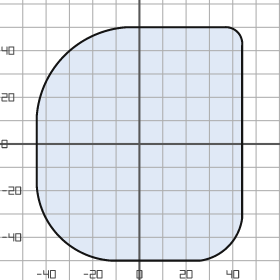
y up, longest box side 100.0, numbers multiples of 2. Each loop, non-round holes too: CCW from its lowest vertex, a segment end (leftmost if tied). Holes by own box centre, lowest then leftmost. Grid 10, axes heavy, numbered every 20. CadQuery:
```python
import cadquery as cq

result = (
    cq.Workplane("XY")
    .moveTo(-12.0, -50.0)
    .lineTo(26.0, -50.0)
    .threePointArc((38.0, -44.0), (44.0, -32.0))
    .lineTo(44.0, 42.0)
    .threePointArc((42.0, 48.0), (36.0, 50.0))
    .lineTo(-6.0, 50.0)
    .threePointArc((-32.0, 38.0), (-44.0, 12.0))
    .lineTo(-44.0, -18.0)
    .threePointArc((-34.0, -40.0), (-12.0, -50.0))
    .close()
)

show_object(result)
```